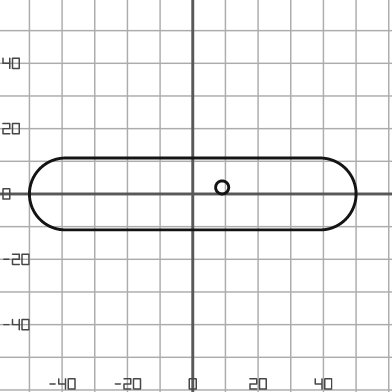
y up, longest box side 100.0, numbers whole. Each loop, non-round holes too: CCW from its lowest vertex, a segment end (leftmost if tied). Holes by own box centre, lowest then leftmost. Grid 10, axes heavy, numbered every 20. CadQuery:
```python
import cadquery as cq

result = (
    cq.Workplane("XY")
    .moveTo(-39.0, -11.0)
    .lineTo(39.0, -11.0)
    .threePointArc((50.0, 0.0), (39.0, 11.0))
    .lineTo(-39.0, 11.0)
    .threePointArc((-50.0, 0.0), (-39.0, -11.0))
    .close()
    .moveTo(9.0, 2.0)
    .circle(2.0)
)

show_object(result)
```